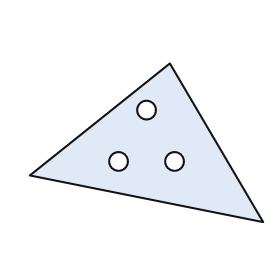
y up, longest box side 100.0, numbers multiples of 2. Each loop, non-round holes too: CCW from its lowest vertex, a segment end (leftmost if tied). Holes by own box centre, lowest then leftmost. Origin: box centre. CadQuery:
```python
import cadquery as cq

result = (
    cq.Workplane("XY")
    .moveTo(50.0, -34.0)
    .lineTo(10.0, 34.0)
    .lineTo(-50.0, -14.0)
    .close()
    .moveTo(-12.0, -8.0)
    .circle(4.0)
    .moveTo(12.0, -8.0)
    .circle(4.0)
    .moveTo(0.0, 14.0)
    .circle(4.0)
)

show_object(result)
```